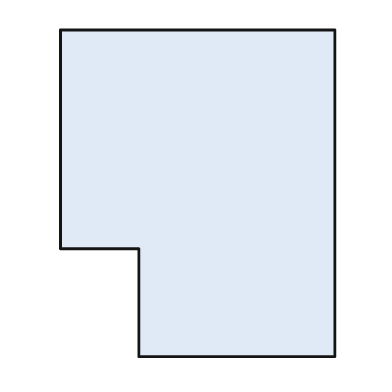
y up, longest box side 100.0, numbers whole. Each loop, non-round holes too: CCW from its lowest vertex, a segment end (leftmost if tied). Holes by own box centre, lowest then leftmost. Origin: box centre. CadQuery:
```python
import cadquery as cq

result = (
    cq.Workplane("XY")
    .moveTo(-18.0, -50.0)
    .lineTo(42.0, -50.0)
    .lineTo(42.0, 50.0)
    .lineTo(-42.0, 50.0)
    .lineTo(-42.0, -17.0)
    .lineTo(-18.0, -17.0)
    .close()
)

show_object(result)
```